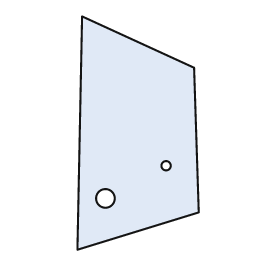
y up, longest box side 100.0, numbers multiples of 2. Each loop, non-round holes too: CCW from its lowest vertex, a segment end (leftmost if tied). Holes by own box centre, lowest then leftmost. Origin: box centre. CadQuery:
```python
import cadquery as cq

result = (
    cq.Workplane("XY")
    .moveTo(-26.0, -50.0)
    .lineTo(26.0, -34.0)
    .lineTo(24.0, 28.0)
    .lineTo(-24.0, 50.0)
    .close()
    .moveTo(-14.0, -28.0)
    .circle(4.0)
    .moveTo(12.0, -14.0)
    .circle(2.0)
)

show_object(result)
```